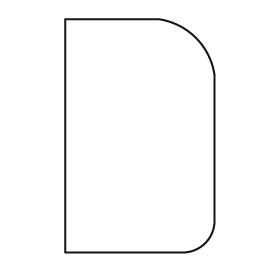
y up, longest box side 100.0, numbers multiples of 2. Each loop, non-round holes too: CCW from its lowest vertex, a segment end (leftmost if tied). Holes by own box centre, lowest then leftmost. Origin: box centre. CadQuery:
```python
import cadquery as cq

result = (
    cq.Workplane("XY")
    .moveTo(-32.0, -50.0)
    .lineTo(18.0, -50.0)
    .threePointArc((28.0, -46.0), (32.0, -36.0))
    .lineTo(32.0, 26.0)
    .threePointArc((24.0, 42.0), (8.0, 50.0))
    .lineTo(-32.0, 50.0)
    .close()
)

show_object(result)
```